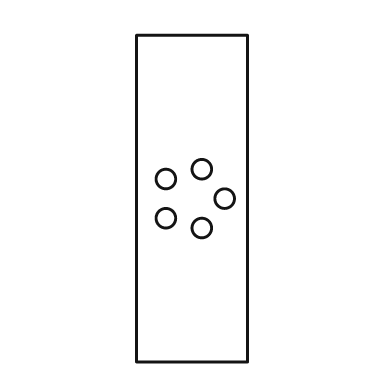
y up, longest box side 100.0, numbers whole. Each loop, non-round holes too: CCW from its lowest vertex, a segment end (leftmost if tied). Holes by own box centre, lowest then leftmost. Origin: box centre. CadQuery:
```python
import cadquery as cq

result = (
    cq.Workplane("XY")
    .moveTo(-17.0, -50.0)
    .lineTo(17.0, -50.0)
    .lineTo(17.0, 50.0)
    .lineTo(-17.0, 50.0)
    .close()
    .moveTo(3.0, -9.0)
    .circle(3.0)
    .moveTo(-8.0, -6.0)
    .circle(3.0)
    .moveTo(10.0, 0.0)
    .circle(3.0)
    .moveTo(-8.0, 6.0)
    .circle(3.0)
    .moveTo(3.0, 9.0)
    .circle(3.0)
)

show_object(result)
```